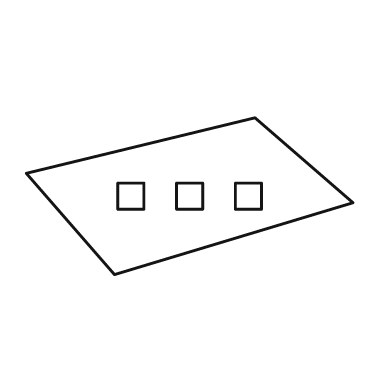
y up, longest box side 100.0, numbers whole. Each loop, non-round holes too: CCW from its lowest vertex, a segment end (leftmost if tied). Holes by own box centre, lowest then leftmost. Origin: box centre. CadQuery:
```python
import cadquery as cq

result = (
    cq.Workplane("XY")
    .moveTo(-23.0, -24.0)
    .lineTo(50.0, -2.0)
    .lineTo(20.0, 24.0)
    .lineTo(-50.0, 7.0)
    .close()
    .moveTo(-22.0, -4.0)
    .lineTo(-14.0, -4.0)
    .lineTo(-14.0, 4.0)
    .lineTo(-22.0, 4.0)
    .close()
    .moveTo(-4.0, -4.0)
    .lineTo(4.0, -4.0)
    .lineTo(4.0, 4.0)
    .lineTo(-4.0, 4.0)
    .close()
    .moveTo(14.0, -4.0)
    .lineTo(22.0, -4.0)
    .lineTo(22.0, 4.0)
    .lineTo(14.0, 4.0)
    .close()
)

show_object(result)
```